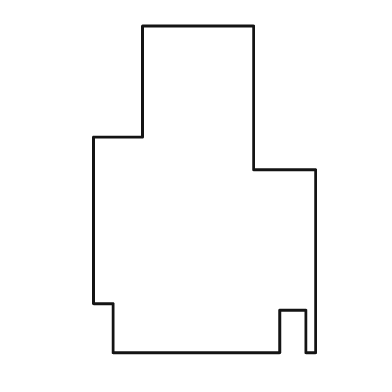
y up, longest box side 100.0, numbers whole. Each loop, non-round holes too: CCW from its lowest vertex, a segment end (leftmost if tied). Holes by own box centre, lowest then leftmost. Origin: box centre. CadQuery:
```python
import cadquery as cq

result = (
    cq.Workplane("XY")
    .moveTo(-28.0, -50.0)
    .lineTo(23.0, -50.0)
    .lineTo(23.0, -37.0)
    .lineTo(31.0, -37.0)
    .lineTo(31.0, -50.0)
    .lineTo(34.0, -50.0)
    .lineTo(34.0, 6.0)
    .lineTo(15.0, 6.0)
    .lineTo(15.0, 50.0)
    .lineTo(-19.0, 50.0)
    .lineTo(-19.0, 16.0)
    .lineTo(-34.0, 16.0)
    .lineTo(-34.0, -35.0)
    .lineTo(-28.0, -35.0)
    .close()
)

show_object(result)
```